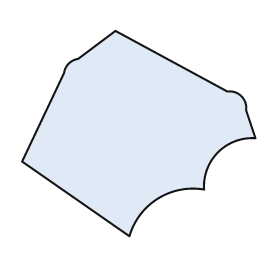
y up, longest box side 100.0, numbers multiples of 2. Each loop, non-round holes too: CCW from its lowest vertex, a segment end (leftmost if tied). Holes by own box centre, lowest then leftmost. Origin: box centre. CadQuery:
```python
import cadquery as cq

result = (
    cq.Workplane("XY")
    .moveTo(-4.0, -44.0)
    .threePointArc((8.0, -28.0), (28.0, -24.0))
    .threePointArc((34.0, -8.0), (50.0, -2.0))
    .lineTo(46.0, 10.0)
    .threePointArc((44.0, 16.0), (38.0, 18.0))
    .lineTo(-10.0, 44.0)
    .lineTo(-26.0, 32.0)
    .threePointArc((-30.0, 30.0), (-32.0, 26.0))
    .lineTo(-50.0, -12.0)
    .close()
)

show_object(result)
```